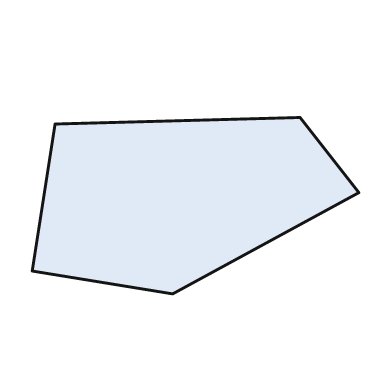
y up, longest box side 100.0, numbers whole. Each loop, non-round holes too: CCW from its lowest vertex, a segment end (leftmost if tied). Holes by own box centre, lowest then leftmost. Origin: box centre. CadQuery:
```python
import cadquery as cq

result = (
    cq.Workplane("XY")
    .moveTo(-7.0, -27.0)
    .lineTo(50.0, 4.0)
    .lineTo(32.0, 27.0)
    .lineTo(-43.0, 25.0)
    .lineTo(-50.0, -20.0)
    .close()
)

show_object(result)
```